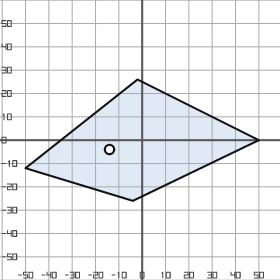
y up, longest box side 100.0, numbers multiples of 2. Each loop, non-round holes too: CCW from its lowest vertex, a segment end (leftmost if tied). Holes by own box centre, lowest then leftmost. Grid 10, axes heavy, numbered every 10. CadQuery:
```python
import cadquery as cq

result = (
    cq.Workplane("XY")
    .moveTo(-4.0, -26.0)
    .lineTo(50.0, 0.0)
    .lineTo(-2.0, 26.0)
    .lineTo(-50.0, -12.0)
    .close()
    .moveTo(-14.0, -4.0)
    .circle(2.0)
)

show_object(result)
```